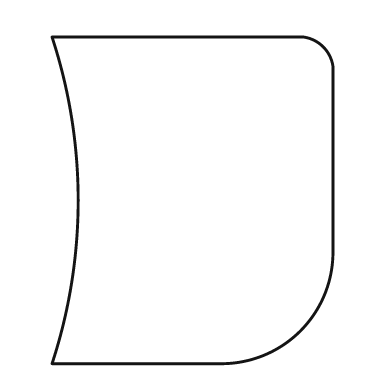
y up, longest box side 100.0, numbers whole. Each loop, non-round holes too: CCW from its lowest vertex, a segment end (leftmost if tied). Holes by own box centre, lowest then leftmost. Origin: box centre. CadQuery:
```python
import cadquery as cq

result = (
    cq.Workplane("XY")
    .moveTo(-43.0, -50.0)
    .lineTo(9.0, -50.0)
    .threePointArc((33.0, -40.0), (43.0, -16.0))
    .lineTo(43.0, 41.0)
    .threePointArc((40.0, 47.0), (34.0, 50.0))
    .lineTo(-43.0, 50.0)
    .threePointArc((-35.0, 0.0), (-43.0, -50.0))
    .close()
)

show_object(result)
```